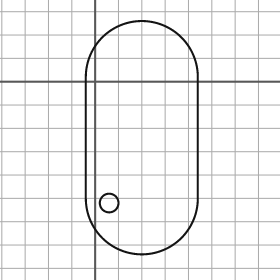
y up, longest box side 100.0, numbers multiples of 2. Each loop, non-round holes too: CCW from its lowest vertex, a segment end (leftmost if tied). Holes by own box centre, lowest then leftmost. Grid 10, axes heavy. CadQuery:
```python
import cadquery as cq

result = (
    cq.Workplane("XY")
    .moveTo(-4.0, -50.0)
    .threePointArc((20.0, -74.0), (44.0, -50.0))
    .lineTo(44.0, 2.0)
    .threePointArc((20.0, 26.0), (-4.0, 2.0))
    .close()
    .moveTo(6.0, -52.0)
    .circle(4.0)
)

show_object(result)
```